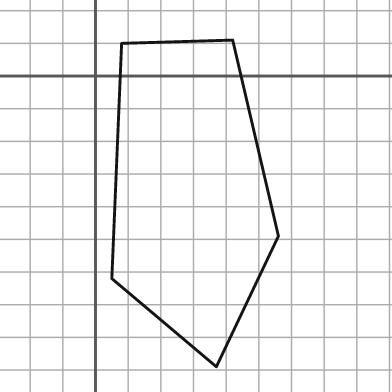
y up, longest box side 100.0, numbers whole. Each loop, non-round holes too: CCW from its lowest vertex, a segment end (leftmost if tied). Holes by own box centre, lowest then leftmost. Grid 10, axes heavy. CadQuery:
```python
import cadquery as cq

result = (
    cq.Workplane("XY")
    .moveTo(37.0, -89.0)
    .lineTo(56.0, -49.0)
    .lineTo(42.0, 11.0)
    .lineTo(8.0, 10.0)
    .lineTo(5.0, -62.0)
    .close()
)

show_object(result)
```